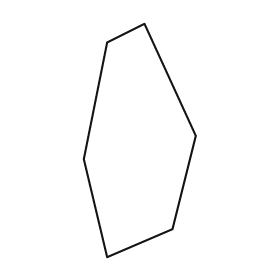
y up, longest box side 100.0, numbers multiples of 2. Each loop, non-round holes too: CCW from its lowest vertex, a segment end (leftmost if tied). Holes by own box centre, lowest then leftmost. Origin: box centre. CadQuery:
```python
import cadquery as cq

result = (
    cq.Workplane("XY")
    .moveTo(-14.0, -50.0)
    .lineTo(14.0, -38.0)
    .lineTo(24.0, 2.0)
    .lineTo(2.0, 50.0)
    .lineTo(-14.0, 42.0)
    .lineTo(-24.0, -8.0)
    .close()
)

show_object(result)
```